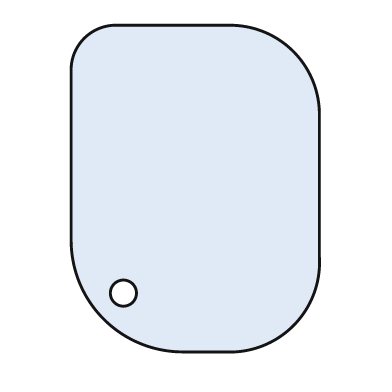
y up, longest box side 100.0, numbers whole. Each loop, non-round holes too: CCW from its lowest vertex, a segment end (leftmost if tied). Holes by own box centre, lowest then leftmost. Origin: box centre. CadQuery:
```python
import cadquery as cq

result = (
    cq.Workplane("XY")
    .moveTo(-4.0, -50.0)
    .lineTo(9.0, -50.0)
    .threePointArc((30.0, -42.0), (38.0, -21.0))
    .lineTo(38.0, 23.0)
    .threePointArc((30.0, 42.0), (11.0, 50.0))
    .lineTo(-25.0, 50.0)
    .threePointArc((-34.0, 46.0), (-38.0, 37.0))
    .lineTo(-38.0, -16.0)
    .threePointArc((-28.0, -40.0), (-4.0, -50.0))
    .close()
    .moveTo(-22.0, -32.0)
    .circle(4.0)
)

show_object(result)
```